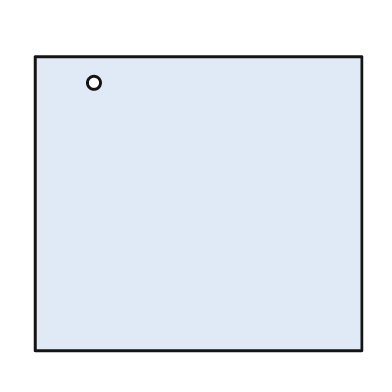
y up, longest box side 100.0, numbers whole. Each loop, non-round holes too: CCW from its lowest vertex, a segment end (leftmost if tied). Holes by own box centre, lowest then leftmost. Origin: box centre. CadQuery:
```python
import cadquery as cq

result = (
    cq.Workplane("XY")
    .moveTo(-50.0, -45.0)
    .lineTo(50.0, -45.0)
    .lineTo(50.0, 45.0)
    .lineTo(-50.0, 45.0)
    .close()
    .moveTo(-32.0, 37.0)
    .circle(2.0)
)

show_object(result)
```